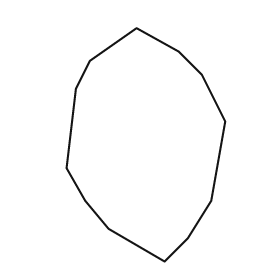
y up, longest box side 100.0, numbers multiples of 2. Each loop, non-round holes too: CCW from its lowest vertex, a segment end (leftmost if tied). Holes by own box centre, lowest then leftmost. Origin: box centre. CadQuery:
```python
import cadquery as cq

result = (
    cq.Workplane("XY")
    .moveTo(8.0, -50.0)
    .lineTo(18.0, -40.0)
    .lineTo(28.0, -24.0)
    .lineTo(34.0, 10.0)
    .lineTo(24.0, 30.0)
    .lineTo(14.0, 40.0)
    .lineTo(-4.0, 50.0)
    .lineTo(-24.0, 36.0)
    .lineTo(-30.0, 24.0)
    .lineTo(-34.0, -10.0)
    .lineTo(-26.0, -24.0)
    .lineTo(-16.0, -36.0)
    .close()
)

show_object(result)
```